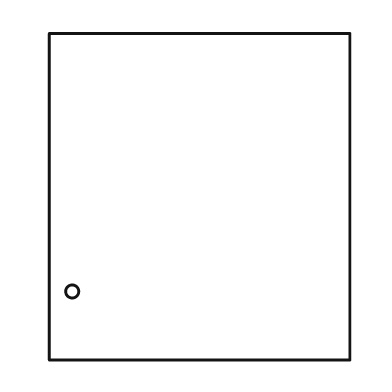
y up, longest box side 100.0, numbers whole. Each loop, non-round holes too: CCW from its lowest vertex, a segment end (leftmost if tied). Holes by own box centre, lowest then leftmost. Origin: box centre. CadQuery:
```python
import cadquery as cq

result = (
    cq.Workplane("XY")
    .moveTo(-46.0, -50.0)
    .lineTo(46.0, -50.0)
    .lineTo(46.0, 50.0)
    .lineTo(-46.0, 50.0)
    .close()
    .moveTo(-39.0, -29.0)
    .circle(2.0)
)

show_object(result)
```